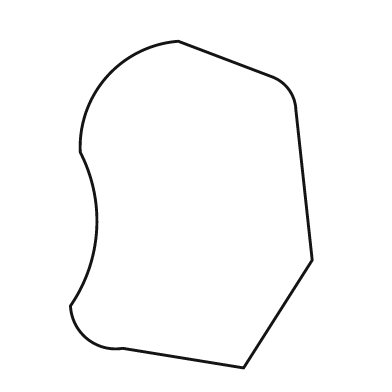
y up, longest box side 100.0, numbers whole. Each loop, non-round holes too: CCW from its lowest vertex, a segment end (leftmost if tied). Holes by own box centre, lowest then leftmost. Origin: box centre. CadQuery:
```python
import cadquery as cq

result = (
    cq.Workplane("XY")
    .moveTo(16.0, -50.0)
    .lineTo(37.0, -17.0)
    .lineTo(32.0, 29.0)
    .threePointArc((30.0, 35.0), (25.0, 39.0))
    .lineTo(-4.0, 50.0)
    .threePointArc((-26.0, 39.0), (-34.0, 16.0))
    .threePointArc((-29.0, -8.0), (-37.0, -31.0))
    .threePointArc((-32.0, -41.0), (-21.0, -44.0))
    .close()
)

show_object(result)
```